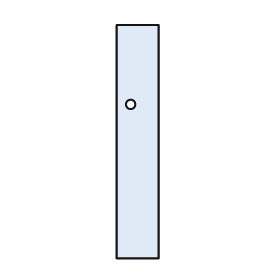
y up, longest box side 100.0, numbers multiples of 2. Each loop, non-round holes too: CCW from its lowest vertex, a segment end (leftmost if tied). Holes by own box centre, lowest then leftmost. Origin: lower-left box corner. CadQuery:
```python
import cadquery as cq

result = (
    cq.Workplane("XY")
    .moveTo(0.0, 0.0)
    .lineTo(18.0, 0.0)
    .lineTo(18.0, 100.0)
    .lineTo(0.0, 100.0)
    .close()
    .moveTo(6.0, 66.0)
    .circle(2.0)
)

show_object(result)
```